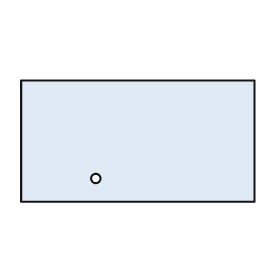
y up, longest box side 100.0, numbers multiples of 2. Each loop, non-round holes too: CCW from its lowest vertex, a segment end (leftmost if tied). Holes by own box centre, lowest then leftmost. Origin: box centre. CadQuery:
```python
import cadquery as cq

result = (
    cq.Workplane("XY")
    .moveTo(-50.0, -26.0)
    .lineTo(50.0, -26.0)
    .lineTo(50.0, 26.0)
    .lineTo(-50.0, 26.0)
    .close()
    .moveTo(-18.0, -16.0)
    .circle(2.0)
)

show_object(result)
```